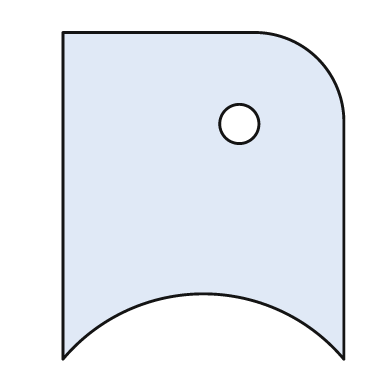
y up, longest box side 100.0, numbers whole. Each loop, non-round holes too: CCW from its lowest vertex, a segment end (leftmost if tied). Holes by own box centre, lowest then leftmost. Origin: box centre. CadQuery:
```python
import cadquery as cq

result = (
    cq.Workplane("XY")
    .moveTo(-43.0, -50.0)
    .threePointArc((0.0, -30.0), (43.0, -50.0))
    .lineTo(43.0, 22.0)
    .threePointArc((35.0, 42.0), (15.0, 50.0))
    .lineTo(-43.0, 50.0)
    .close()
    .moveTo(11.0, 22.0)
    .circle(6.0)
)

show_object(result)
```